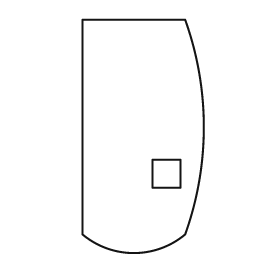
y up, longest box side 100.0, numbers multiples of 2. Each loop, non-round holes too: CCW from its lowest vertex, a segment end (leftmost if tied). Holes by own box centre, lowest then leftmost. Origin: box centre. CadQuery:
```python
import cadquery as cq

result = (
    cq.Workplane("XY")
    .moveTo(-26.0, -42.0)
    .threePointArc((-4.0, -50.0), (18.0, -42.0))
    .threePointArc((26.0, 4.0), (18.0, 50.0))
    .lineTo(-26.0, 50.0)
    .close()
    .moveTo(4.0, -22.0)
    .lineTo(16.0, -22.0)
    .lineTo(16.0, -10.0)
    .lineTo(4.0, -10.0)
    .close()
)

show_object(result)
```